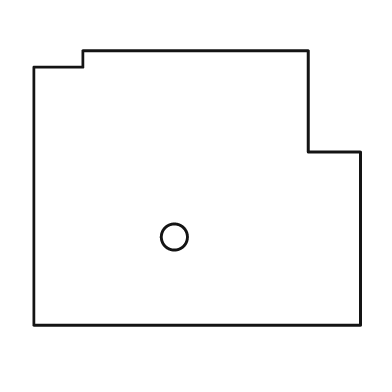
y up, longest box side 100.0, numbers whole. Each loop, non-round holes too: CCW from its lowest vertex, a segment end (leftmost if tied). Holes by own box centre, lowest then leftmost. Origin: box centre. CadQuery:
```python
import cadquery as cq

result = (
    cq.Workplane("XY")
    .moveTo(-50.0, -42.0)
    .lineTo(50.0, -42.0)
    .lineTo(50.0, 11.0)
    .lineTo(34.0, 11.0)
    .lineTo(34.0, 42.0)
    .lineTo(-35.0, 42.0)
    .lineTo(-35.0, 37.0)
    .lineTo(-50.0, 37.0)
    .close()
    .moveTo(-7.0, -15.0)
    .circle(4.0)
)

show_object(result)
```